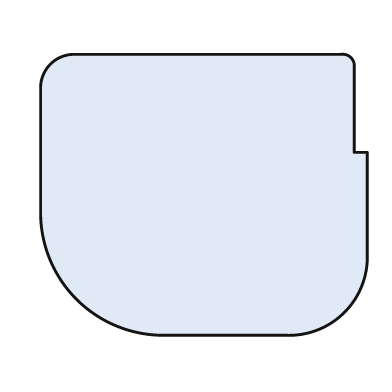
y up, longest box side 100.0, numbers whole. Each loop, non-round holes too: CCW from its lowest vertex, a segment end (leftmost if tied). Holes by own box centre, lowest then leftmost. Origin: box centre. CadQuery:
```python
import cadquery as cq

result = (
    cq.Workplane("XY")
    .moveTo(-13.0, -43.0)
    .lineTo(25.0, -43.0)
    .threePointArc((43.0, -36.0), (50.0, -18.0))
    .lineTo(50.0, 13.0)
    .lineTo(46.0, 13.0)
    .lineTo(46.0, 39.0)
    .threePointArc((45.0, 42.0), (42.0, 43.0))
    .lineTo(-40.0, 43.0)
    .threePointArc((-47.0, 40.0), (-50.0, 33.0))
    .lineTo(-50.0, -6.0)
    .threePointArc((-39.0, -32.0), (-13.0, -43.0))
    .close()
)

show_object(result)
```